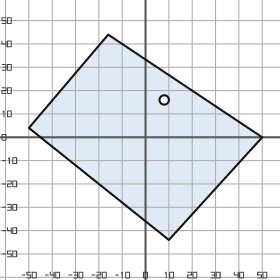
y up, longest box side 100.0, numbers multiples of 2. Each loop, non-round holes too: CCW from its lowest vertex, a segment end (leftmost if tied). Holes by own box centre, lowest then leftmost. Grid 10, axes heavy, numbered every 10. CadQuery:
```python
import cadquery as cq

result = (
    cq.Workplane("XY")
    .moveTo(10.0, -44.0)
    .lineTo(50.0, 0.0)
    .lineTo(-16.0, 44.0)
    .lineTo(-50.0, 4.0)
    .close()
    .moveTo(8.0, 16.0)
    .circle(2.0)
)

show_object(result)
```